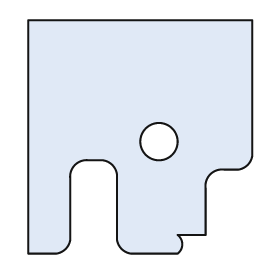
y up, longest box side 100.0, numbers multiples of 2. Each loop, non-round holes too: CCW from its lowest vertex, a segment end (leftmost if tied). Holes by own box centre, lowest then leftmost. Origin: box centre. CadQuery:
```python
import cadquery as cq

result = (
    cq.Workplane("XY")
    .moveTo(-48.0, -50.0)
    .lineTo(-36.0, -50.0)
    .threePointArc((-32.0, -48.0), (-30.0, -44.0))
    .lineTo(-30.0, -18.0)
    .threePointArc((-28.0, -12.0), (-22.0, -10.0))
    .lineTo(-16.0, -10.0)
    .threePointArc((-12.0, -12.0), (-10.0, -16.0))
    .lineTo(-10.0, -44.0)
    .threePointArc((-8.0, -48.0), (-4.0, -50.0))
    .lineTo(16.0, -50.0)
    .threePointArc((18.0, -46.0), (16.0, -42.0))
    .lineTo(28.0, -42.0)
    .lineTo(28.0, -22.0)
    .threePointArc((30.0, -16.0), (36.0, -14.0))
    .lineTo(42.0, -14.0)
    .threePointArc((46.0, -12.0), (48.0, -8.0))
    .lineTo(48.0, 50.0)
    .lineTo(-48.0, 50.0)
    .close()
    .moveTo(8.0, -2.0)
    .circle(8.0)
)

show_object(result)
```